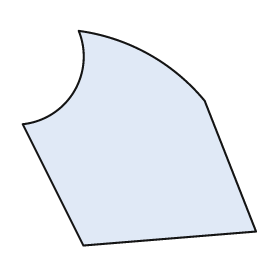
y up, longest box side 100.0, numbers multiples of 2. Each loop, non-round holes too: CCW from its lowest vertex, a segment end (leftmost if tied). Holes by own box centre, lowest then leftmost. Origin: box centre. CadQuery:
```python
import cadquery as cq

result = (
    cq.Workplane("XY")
    .moveTo(-24.0, -46.0)
    .lineTo(50.0, -40.0)
    .lineTo(28.0, 16.0)
    .threePointArc((4.0, 36.0), (-26.0, 46.0))
    .threePointArc((-28.0, 20.0), (-50.0, 6.0))
    .close()
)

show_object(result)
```